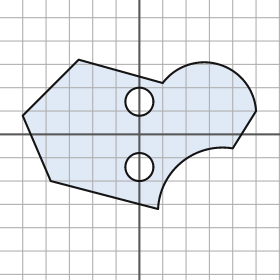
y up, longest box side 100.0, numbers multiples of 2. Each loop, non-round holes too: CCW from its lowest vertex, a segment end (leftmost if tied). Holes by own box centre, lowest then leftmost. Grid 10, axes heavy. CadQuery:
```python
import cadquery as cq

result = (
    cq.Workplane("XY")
    .moveTo(8.0, -32.0)
    .threePointArc((18.0, -12.0), (40.0, -6.0))
    .lineTo(50.0, 10.0)
    .threePointArc((34.0, 30.0), (10.0, 22.0))
    .lineTo(-26.0, 32.0)
    .lineTo(-50.0, 8.0)
    .lineTo(-38.0, -20.0)
    .close()
    .moveTo(0.0, -14.0)
    .circle(6.0)
    .moveTo(0.0, 14.0)
    .circle(6.0)
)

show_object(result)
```